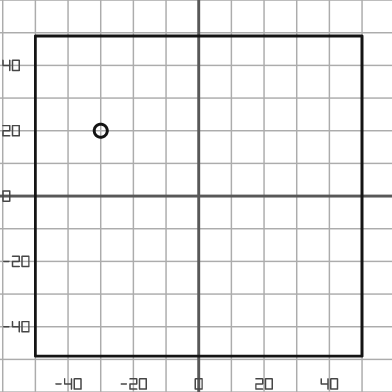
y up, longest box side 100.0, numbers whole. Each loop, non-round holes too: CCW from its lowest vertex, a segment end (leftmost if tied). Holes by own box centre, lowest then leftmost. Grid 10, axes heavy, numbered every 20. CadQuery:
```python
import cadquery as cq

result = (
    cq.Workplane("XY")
    .moveTo(-50.0, -49.0)
    .lineTo(50.0, -49.0)
    .lineTo(50.0, 49.0)
    .lineTo(-50.0, 49.0)
    .close()
    .moveTo(-30.0, 20.0)
    .circle(2.0)
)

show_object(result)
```